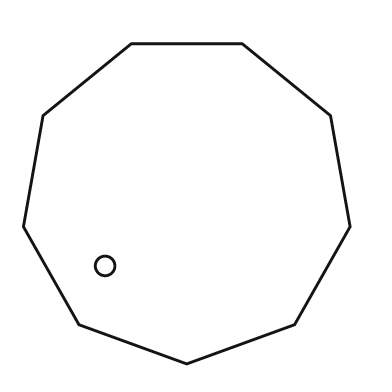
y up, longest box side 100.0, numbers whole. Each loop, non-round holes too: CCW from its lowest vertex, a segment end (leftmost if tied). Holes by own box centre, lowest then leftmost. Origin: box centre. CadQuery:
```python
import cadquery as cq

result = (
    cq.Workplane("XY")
    .moveTo(0.0, -49.0)
    .lineTo(33.0, -37.0)
    .lineTo(50.0, -7.0)
    .lineTo(44.0, 27.0)
    .lineTo(17.0, 49.0)
    .lineTo(-17.0, 49.0)
    .lineTo(-44.0, 27.0)
    .lineTo(-50.0, -7.0)
    .lineTo(-33.0, -37.0)
    .close()
    .moveTo(-25.0, -19.0)
    .circle(3.0)
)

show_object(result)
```